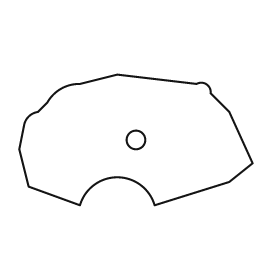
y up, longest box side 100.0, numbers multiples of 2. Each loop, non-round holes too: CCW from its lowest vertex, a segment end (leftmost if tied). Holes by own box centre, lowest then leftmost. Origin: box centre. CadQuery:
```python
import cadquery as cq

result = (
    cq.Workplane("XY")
    .moveTo(-24.0, -28.0)
    .threePointArc((-8.0, -16.0), (8.0, -28.0))
    .lineTo(40.0, -18.0)
    .lineTo(50.0, -10.0)
    .lineTo(40.0, 12.0)
    .lineTo(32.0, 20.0)
    .threePointArc((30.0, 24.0), (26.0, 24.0))
    .lineTo(-8.0, 28.0)
    .lineTo(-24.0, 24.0)
    .threePointArc((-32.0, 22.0), (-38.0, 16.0))
    .lineTo(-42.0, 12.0)
    .threePointArc((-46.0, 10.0), (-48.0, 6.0))
    .lineTo(-50.0, -4.0)
    .lineTo(-46.0, -20.0)
    .close()
    .moveTo(0.0, 0.0)
    .circle(4.0)
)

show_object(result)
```